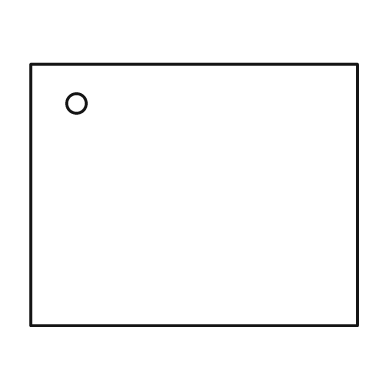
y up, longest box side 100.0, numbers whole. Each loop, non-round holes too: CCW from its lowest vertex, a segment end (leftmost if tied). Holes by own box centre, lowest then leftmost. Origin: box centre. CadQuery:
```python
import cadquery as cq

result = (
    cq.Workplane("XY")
    .moveTo(-50.0, -40.0)
    .lineTo(50.0, -40.0)
    .lineTo(50.0, 40.0)
    .lineTo(-50.0, 40.0)
    .close()
    .moveTo(-36.0, 28.0)
    .circle(3.0)
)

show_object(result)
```